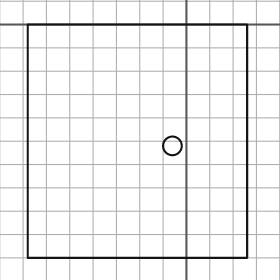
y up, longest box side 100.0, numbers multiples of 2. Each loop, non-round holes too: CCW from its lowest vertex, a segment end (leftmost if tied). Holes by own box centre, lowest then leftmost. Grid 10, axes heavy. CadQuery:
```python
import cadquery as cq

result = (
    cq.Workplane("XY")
    .moveTo(-68.0, -100.0)
    .lineTo(26.0, -100.0)
    .lineTo(26.0, 0.0)
    .lineTo(-68.0, 0.0)
    .close()
    .moveTo(-6.0, -52.0)
    .circle(4.0)
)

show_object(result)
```